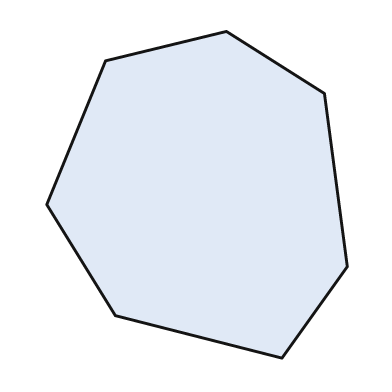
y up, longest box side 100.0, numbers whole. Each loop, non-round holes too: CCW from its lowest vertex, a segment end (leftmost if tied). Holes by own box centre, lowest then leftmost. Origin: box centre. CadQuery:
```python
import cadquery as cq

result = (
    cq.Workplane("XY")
    .moveTo(26.0, -50.0)
    .lineTo(46.0, -22.0)
    .lineTo(39.0, 31.0)
    .lineTo(9.0, 50.0)
    .lineTo(-28.0, 41.0)
    .lineTo(-46.0, -3.0)
    .lineTo(-25.0, -37.0)
    .close()
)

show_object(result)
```